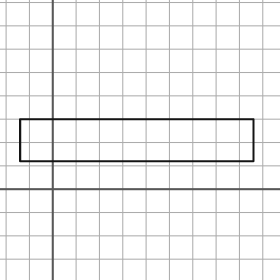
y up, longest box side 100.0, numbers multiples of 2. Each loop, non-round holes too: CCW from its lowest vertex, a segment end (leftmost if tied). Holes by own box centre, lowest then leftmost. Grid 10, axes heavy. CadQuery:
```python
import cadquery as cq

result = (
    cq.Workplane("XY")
    .moveTo(-14.0, 12.0)
    .lineTo(86.0, 12.0)
    .lineTo(86.0, 30.0)
    .lineTo(-14.0, 30.0)
    .close()
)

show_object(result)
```